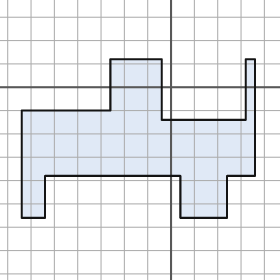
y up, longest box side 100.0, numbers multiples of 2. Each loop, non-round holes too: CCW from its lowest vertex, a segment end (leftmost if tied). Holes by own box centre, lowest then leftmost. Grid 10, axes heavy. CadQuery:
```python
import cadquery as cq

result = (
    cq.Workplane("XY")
    .moveTo(-64.0, -56.0)
    .lineTo(-54.0, -56.0)
    .lineTo(-54.0, -38.0)
    .lineTo(4.0, -38.0)
    .lineTo(4.0, -56.0)
    .lineTo(24.0, -56.0)
    .lineTo(24.0, -38.0)
    .lineTo(36.0, -38.0)
    .lineTo(36.0, 12.0)
    .lineTo(32.0, 12.0)
    .lineTo(32.0, -14.0)
    .lineTo(-4.0, -14.0)
    .lineTo(-4.0, 12.0)
    .lineTo(-26.0, 12.0)
    .lineTo(-26.0, -10.0)
    .lineTo(-64.0, -10.0)
    .close()
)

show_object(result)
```